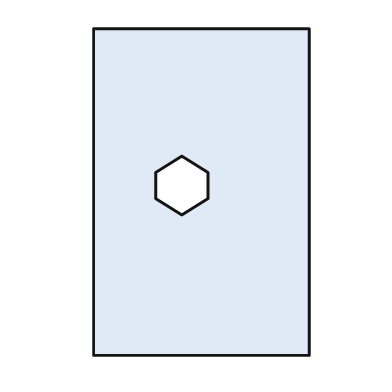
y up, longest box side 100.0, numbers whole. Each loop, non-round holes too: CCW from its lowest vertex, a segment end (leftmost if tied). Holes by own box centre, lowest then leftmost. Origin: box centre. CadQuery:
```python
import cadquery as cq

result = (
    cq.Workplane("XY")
    .moveTo(-33.0, -50.0)
    .lineTo(33.0, -50.0)
    .lineTo(33.0, 50.0)
    .lineTo(-33.0, 50.0)
    .close()
    .moveTo(-6.0, -7.0)
    .lineTo(2.0, -2.0)
    .lineTo(2.0, 6.0)
    .lineTo(-6.0, 11.0)
    .lineTo(-14.0, 6.0)
    .lineTo(-14.0, -2.0)
    .close()
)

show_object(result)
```